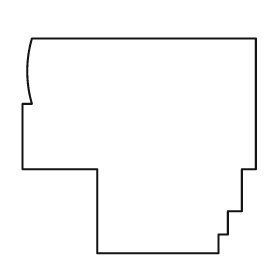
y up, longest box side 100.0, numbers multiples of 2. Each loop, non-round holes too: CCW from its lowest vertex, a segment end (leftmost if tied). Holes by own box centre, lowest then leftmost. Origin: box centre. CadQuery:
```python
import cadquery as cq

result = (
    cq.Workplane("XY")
    .moveTo(-18.0, -46.0)
    .lineTo(34.0, -46.0)
    .lineTo(34.0, -38.0)
    .lineTo(38.0, -38.0)
    .lineTo(38.0, -28.0)
    .lineTo(44.0, -28.0)
    .lineTo(44.0, -10.0)
    .lineTo(50.0, -10.0)
    .lineTo(50.0, 46.0)
    .lineTo(-46.0, 46.0)
    .threePointArc((-48.0, 32.0), (-46.0, 18.0))
    .lineTo(-50.0, 18.0)
    .lineTo(-50.0, -10.0)
    .lineTo(-18.0, -10.0)
    .close()
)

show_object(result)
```